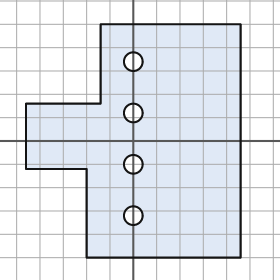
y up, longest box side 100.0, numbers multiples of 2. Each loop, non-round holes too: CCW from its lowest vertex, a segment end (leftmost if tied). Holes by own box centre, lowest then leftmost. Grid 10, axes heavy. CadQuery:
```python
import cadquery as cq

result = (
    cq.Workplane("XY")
    .moveTo(-20.0, -50.0)
    .lineTo(46.0, -50.0)
    .lineTo(46.0, 50.0)
    .lineTo(-14.0, 50.0)
    .lineTo(-14.0, 16.0)
    .lineTo(-46.0, 16.0)
    .lineTo(-46.0, -12.0)
    .lineTo(-20.0, -12.0)
    .close()
    .moveTo(0.0, -32.0)
    .circle(4.0)
    .moveTo(0.0, -10.0)
    .circle(4.0)
    .moveTo(0.0, 12.0)
    .circle(4.0)
    .moveTo(0.0, 34.0)
    .circle(4.0)
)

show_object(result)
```